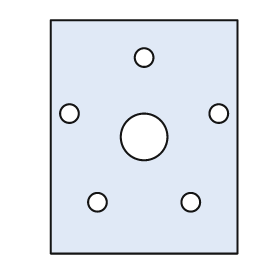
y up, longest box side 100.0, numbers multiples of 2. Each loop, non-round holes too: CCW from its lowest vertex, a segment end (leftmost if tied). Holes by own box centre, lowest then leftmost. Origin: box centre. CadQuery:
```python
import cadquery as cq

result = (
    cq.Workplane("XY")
    .moveTo(-40.0, -50.0)
    .lineTo(40.0, -50.0)
    .lineTo(40.0, 50.0)
    .lineTo(-40.0, 50.0)
    .close()
    .moveTo(-20.0, -28.0)
    .circle(4.0)
    .moveTo(20.0, -28.0)
    .circle(4.0)
    .moveTo(0.0, 0.0)
    .circle(10.0)
    .moveTo(-32.0, 10.0)
    .circle(4.0)
    .moveTo(32.0, 10.0)
    .circle(4.0)
    .moveTo(0.0, 34.0)
    .circle(4.0)
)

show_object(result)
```